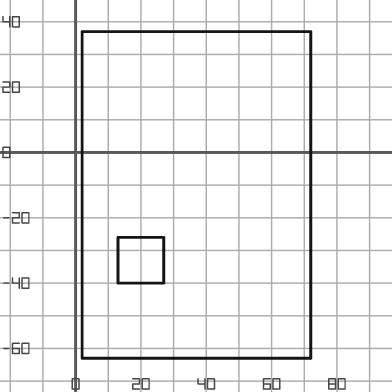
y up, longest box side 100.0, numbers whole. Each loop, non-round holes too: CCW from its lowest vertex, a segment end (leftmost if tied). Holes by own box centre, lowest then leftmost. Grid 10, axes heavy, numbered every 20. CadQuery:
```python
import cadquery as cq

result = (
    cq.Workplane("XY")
    .moveTo(2.0, -63.0)
    .lineTo(72.0, -63.0)
    .lineTo(72.0, 37.0)
    .lineTo(2.0, 37.0)
    .close()
    .moveTo(13.0, -40.0)
    .lineTo(27.0, -40.0)
    .lineTo(27.0, -26.0)
    .lineTo(13.0, -26.0)
    .close()
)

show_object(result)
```